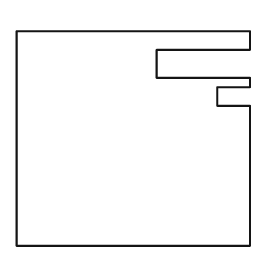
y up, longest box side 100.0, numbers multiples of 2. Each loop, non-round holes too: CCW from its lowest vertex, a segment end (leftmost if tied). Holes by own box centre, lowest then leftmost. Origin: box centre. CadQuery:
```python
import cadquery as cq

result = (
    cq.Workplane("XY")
    .moveTo(-50.0, -46.0)
    .lineTo(50.0, -46.0)
    .lineTo(50.0, 14.0)
    .lineTo(36.0, 14.0)
    .lineTo(36.0, 22.0)
    .lineTo(50.0, 22.0)
    .lineTo(50.0, 26.0)
    .lineTo(10.0, 26.0)
    .lineTo(10.0, 38.0)
    .lineTo(50.0, 38.0)
    .lineTo(50.0, 46.0)
    .lineTo(-50.0, 46.0)
    .close()
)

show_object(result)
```